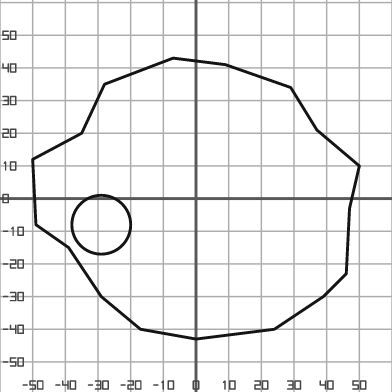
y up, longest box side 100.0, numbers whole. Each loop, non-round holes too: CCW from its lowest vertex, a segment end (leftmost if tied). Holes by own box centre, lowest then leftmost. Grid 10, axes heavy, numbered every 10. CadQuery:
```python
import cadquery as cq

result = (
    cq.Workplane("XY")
    .moveTo(0.0, -43.0)
    .lineTo(24.0, -40.0)
    .lineTo(39.0, -30.0)
    .lineTo(46.0, -23.0)
    .lineTo(47.0, -3.0)
    .lineTo(50.0, 10.0)
    .lineTo(37.0, 21.0)
    .lineTo(29.0, 34.0)
    .lineTo(9.0, 41.0)
    .lineTo(-7.0, 43.0)
    .lineTo(-28.0, 35.0)
    .lineTo(-35.0, 20.0)
    .lineTo(-50.0, 12.0)
    .lineTo(-49.0, -8.0)
    .lineTo(-39.0, -15.0)
    .lineTo(-29.0, -30.0)
    .lineTo(-17.0, -40.0)
    .close()
    .moveTo(-29.0, -8.0)
    .circle(9.0)
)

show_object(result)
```